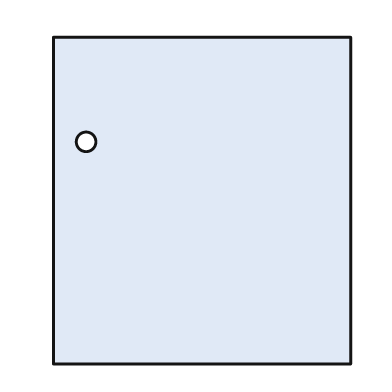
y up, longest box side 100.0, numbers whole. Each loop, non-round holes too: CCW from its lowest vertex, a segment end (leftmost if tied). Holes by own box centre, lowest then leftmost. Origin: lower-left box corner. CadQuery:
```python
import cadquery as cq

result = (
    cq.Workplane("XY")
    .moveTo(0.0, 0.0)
    .lineTo(91.0, 0.0)
    .lineTo(91.0, 100.0)
    .lineTo(0.0, 100.0)
    .close()
    .moveTo(10.0, 68.0)
    .circle(3.0)
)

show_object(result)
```